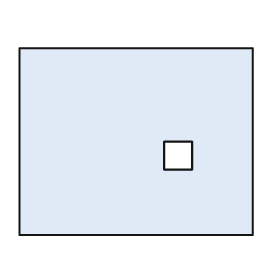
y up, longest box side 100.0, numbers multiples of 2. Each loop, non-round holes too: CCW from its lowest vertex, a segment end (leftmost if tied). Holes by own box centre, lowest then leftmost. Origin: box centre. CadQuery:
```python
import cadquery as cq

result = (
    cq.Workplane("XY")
    .moveTo(-50.0, -40.0)
    .lineTo(50.0, -40.0)
    .lineTo(50.0, 40.0)
    .lineTo(-50.0, 40.0)
    .close()
    .moveTo(12.0, -12.0)
    .lineTo(24.0, -12.0)
    .lineTo(24.0, 0.0)
    .lineTo(12.0, 0.0)
    .close()
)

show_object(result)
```